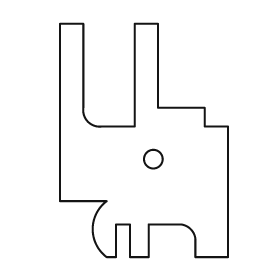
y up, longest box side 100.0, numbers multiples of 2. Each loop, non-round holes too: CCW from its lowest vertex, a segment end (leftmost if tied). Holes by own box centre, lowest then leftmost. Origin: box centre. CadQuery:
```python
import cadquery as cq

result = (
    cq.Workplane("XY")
    .moveTo(-16.0, -50.0)
    .lineTo(-12.0, -50.0)
    .lineTo(-12.0, -36.0)
    .lineTo(-6.0, -36.0)
    .lineTo(-6.0, -50.0)
    .lineTo(2.0, -50.0)
    .lineTo(2.0, -36.0)
    .lineTo(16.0, -36.0)
    .threePointArc((20.0, -38.0), (22.0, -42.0))
    .lineTo(22.0, -50.0)
    .lineTo(36.0, -50.0)
    .lineTo(36.0, 6.0)
    .lineTo(26.0, 6.0)
    .lineTo(26.0, 14.0)
    .lineTo(6.0, 14.0)
    .lineTo(6.0, 50.0)
    .lineTo(-4.0, 50.0)
    .lineTo(-4.0, 6.0)
    .lineTo(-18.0, 6.0)
    .threePointArc((-24.0, 8.0), (-26.0, 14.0))
    .lineTo(-26.0, 50.0)
    .lineTo(-36.0, 50.0)
    .lineTo(-36.0, -26.0)
    .lineTo(-16.0, -26.0)
    .threePointArc((-22.0, -38.0), (-16.0, -50.0))
    .close()
    .moveTo(4.0, -8.0)
    .circle(4.0)
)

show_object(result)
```